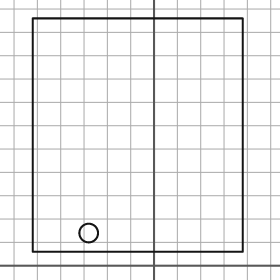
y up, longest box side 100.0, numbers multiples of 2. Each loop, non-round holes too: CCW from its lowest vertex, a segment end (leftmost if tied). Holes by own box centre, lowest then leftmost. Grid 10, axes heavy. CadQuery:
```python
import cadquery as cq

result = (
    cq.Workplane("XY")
    .moveTo(-52.0, 6.0)
    .lineTo(38.0, 6.0)
    .lineTo(38.0, 106.0)
    .lineTo(-52.0, 106.0)
    .close()
    .moveTo(-28.0, 14.0)
    .circle(4.0)
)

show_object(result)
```